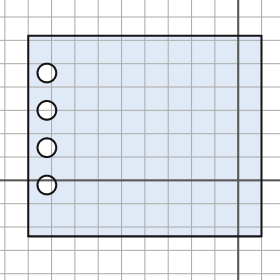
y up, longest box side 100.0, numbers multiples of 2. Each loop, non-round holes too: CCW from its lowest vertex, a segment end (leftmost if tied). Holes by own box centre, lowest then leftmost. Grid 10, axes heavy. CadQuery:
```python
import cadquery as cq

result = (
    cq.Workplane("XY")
    .moveTo(-90.0, -24.0)
    .lineTo(10.0, -24.0)
    .lineTo(10.0, 62.0)
    .lineTo(-90.0, 62.0)
    .close()
    .moveTo(-82.0, -2.0)
    .circle(4.0)
    .moveTo(-82.0, 14.0)
    .circle(4.0)
    .moveTo(-82.0, 30.0)
    .circle(4.0)
    .moveTo(-82.0, 46.0)
    .circle(4.0)
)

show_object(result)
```